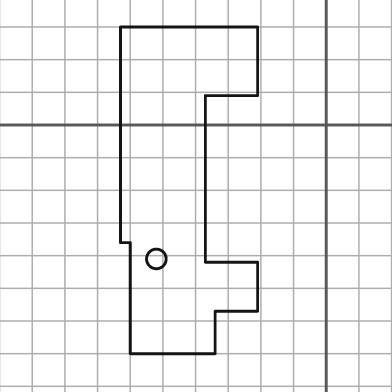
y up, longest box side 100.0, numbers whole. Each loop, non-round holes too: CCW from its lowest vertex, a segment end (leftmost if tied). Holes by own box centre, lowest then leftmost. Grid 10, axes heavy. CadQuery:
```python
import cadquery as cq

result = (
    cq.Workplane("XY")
    .moveTo(-60.0, -70.0)
    .lineTo(-34.0, -70.0)
    .lineTo(-34.0, -57.0)
    .lineTo(-21.0, -57.0)
    .lineTo(-21.0, -42.0)
    .lineTo(-37.0, -42.0)
    .lineTo(-37.0, 9.0)
    .lineTo(-21.0, 9.0)
    .lineTo(-21.0, 30.0)
    .lineTo(-63.0, 30.0)
    .lineTo(-63.0, -36.0)
    .lineTo(-60.0, -36.0)
    .close()
    .moveTo(-52.0, -41.0)
    .circle(3.0)
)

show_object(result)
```